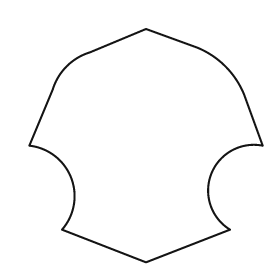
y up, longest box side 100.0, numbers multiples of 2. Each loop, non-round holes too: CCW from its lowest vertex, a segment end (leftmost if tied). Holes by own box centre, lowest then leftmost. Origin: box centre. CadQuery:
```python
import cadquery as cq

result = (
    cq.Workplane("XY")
    .moveTo(0.0, -50.0)
    .lineTo(36.0, -36.0)
    .threePointArc((28.0, -12.0), (50.0, 0.0))
    .lineTo(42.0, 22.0)
    .threePointArc((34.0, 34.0), (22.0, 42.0))
    .lineTo(0.0, 50.0)
    .lineTo(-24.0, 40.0)
    .threePointArc((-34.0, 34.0), (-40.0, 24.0))
    .lineTo(-50.0, 0.0)
    .threePointArc((-32.0, -14.0), (-36.0, -36.0))
    .close()
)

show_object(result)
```